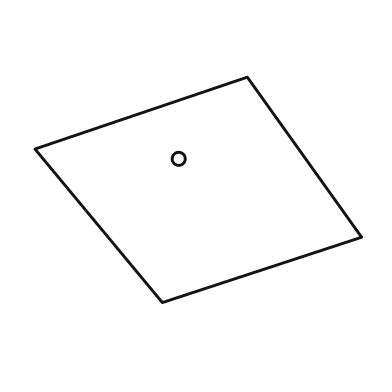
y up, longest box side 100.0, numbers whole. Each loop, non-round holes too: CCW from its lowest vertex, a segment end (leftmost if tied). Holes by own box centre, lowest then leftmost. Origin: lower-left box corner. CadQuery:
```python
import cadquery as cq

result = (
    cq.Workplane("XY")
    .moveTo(39.0, 0.0)
    .lineTo(100.0, 20.0)
    .lineTo(65.0, 69.0)
    .lineTo(0.0, 47.0)
    .close()
    .moveTo(44.0, 44.0)
    .circle(2.0)
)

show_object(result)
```